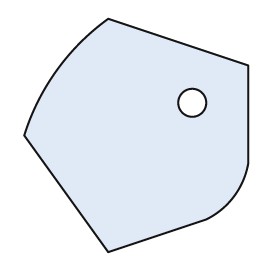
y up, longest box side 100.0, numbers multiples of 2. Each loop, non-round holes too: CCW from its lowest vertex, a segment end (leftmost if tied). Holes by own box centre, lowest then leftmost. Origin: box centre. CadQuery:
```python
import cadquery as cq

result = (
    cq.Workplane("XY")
    .moveTo(-12.0, -50.0)
    .lineTo(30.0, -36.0)
    .threePointArc((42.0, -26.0), (48.0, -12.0))
    .lineTo(48.0, 30.0)
    .lineTo(-12.0, 50.0)
    .threePointArc((-34.0, 28.0), (-48.0, 0.0))
    .close()
    .moveTo(24.0, 14.0)
    .circle(6.0)
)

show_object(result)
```